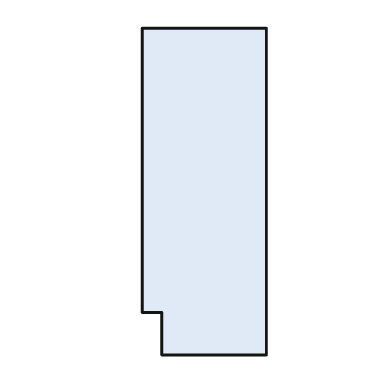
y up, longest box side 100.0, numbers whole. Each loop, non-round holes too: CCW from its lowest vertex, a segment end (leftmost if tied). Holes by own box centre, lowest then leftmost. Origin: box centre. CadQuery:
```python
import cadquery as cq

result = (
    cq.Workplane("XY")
    .moveTo(-13.0, -50.0)
    .lineTo(19.0, -50.0)
    .lineTo(19.0, 50.0)
    .lineTo(-19.0, 50.0)
    .lineTo(-19.0, -37.0)
    .lineTo(-13.0, -37.0)
    .close()
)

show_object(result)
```